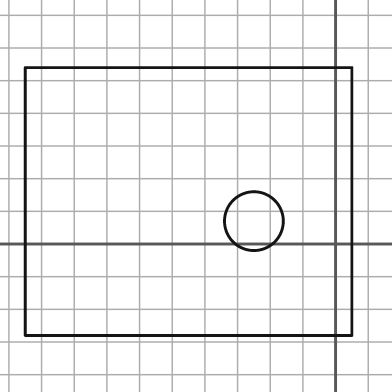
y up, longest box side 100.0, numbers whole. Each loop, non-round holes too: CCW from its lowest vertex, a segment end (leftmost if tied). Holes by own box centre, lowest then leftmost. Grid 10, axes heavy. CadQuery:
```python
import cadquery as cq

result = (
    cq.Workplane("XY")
    .moveTo(-95.0, -28.0)
    .lineTo(5.0, -28.0)
    .lineTo(5.0, 54.0)
    .lineTo(-95.0, 54.0)
    .close()
    .moveTo(-25.0, 7.0)
    .circle(9.0)
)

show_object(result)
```